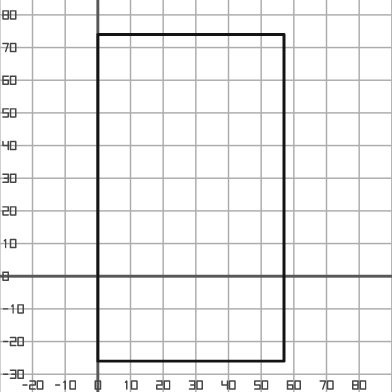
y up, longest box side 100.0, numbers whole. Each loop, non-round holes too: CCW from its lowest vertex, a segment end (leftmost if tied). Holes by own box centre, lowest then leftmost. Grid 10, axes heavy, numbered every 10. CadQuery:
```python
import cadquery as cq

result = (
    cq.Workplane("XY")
    .moveTo(0.0, -26.0)
    .lineTo(57.0, -26.0)
    .lineTo(57.0, 74.0)
    .lineTo(0.0, 74.0)
    .close()
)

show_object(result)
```